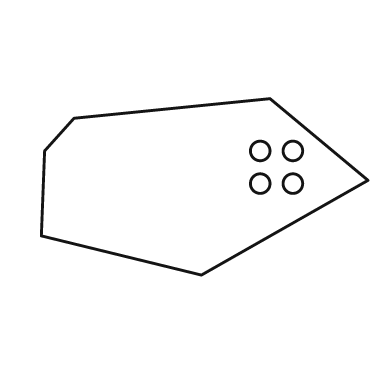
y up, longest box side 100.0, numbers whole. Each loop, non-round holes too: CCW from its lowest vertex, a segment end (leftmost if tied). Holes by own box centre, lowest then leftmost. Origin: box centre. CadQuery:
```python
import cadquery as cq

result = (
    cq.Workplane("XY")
    .moveTo(-1.0, -27.0)
    .lineTo(50.0, 2.0)
    .lineTo(20.0, 27.0)
    .lineTo(-40.0, 21.0)
    .lineTo(-49.0, 11.0)
    .lineTo(-50.0, -15.0)
    .close()
    .moveTo(17.0, 1.0)
    .circle(3.0)
    .moveTo(27.0, 1.0)
    .circle(3.0)
    .moveTo(17.0, 11.0)
    .circle(3.0)
    .moveTo(27.0, 11.0)
    .circle(3.0)
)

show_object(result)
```